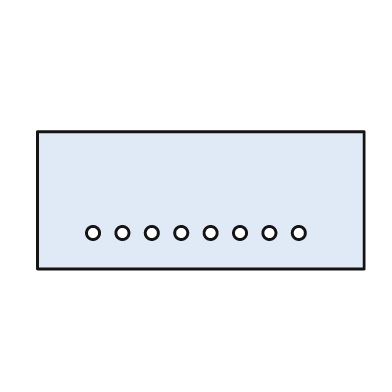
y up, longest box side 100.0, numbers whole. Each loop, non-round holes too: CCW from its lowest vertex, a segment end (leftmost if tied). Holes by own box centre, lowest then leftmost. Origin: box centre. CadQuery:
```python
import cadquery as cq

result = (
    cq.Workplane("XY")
    .moveTo(-50.0, -21.0)
    .lineTo(50.0, -21.0)
    .lineTo(50.0, 21.0)
    .lineTo(-50.0, 21.0)
    .close()
    .moveTo(-33.0, -10.0)
    .circle(2.0)
    .moveTo(-24.0, -10.0)
    .circle(2.0)
    .moveTo(-15.0, -10.0)
    .circle(2.0)
    .moveTo(-6.0, -10.0)
    .circle(2.0)
    .moveTo(3.0, -10.0)
    .circle(2.0)
    .moveTo(12.0, -10.0)
    .circle(2.0)
    .moveTo(21.0, -10.0)
    .circle(2.0)
    .moveTo(30.0, -10.0)
    .circle(2.0)
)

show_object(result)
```